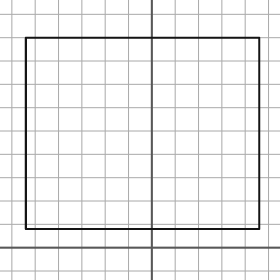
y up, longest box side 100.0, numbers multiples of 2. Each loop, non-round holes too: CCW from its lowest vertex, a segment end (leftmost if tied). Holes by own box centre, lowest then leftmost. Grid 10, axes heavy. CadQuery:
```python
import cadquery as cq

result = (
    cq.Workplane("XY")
    .moveTo(-54.0, 8.0)
    .lineTo(46.0, 8.0)
    .lineTo(46.0, 90.0)
    .lineTo(-54.0, 90.0)
    .close()
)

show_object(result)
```